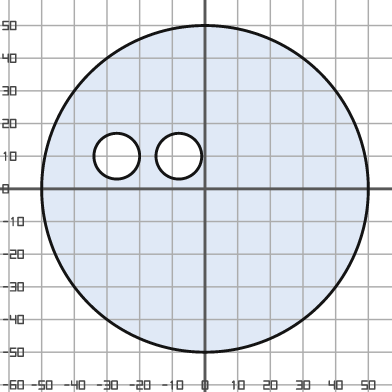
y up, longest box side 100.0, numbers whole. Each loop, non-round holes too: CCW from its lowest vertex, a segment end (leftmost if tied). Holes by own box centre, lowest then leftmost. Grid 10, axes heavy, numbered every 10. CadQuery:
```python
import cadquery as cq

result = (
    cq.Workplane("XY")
    .moveTo(0.0, 0.0)
    .circle(50.0)
    .moveTo(-27.0, 10.0)
    .circle(7.0)
    .moveTo(-8.0, 10.0)
    .circle(7.0)
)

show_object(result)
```